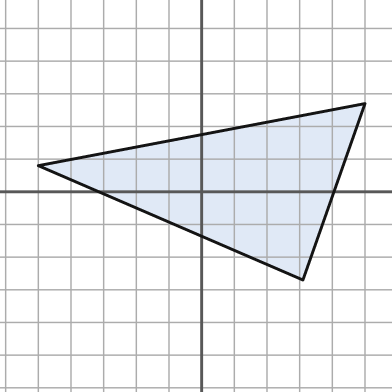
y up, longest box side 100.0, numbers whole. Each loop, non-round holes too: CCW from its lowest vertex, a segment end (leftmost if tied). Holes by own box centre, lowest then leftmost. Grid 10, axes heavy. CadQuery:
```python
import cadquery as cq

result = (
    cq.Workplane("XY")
    .moveTo(31.0, -27.0)
    .lineTo(50.0, 27.0)
    .lineTo(-50.0, 8.0)
    .close()
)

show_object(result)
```